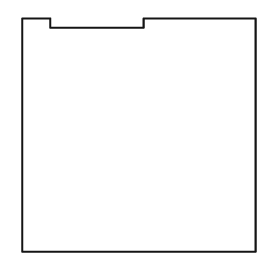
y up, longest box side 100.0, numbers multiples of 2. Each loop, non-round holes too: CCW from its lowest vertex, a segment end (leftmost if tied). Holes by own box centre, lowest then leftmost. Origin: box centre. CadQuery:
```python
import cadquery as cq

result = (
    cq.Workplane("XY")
    .moveTo(-50.0, -50.0)
    .lineTo(50.0, -50.0)
    .lineTo(50.0, 50.0)
    .lineTo(2.0, 50.0)
    .lineTo(2.0, 46.0)
    .lineTo(-38.0, 46.0)
    .lineTo(-38.0, 50.0)
    .lineTo(-50.0, 50.0)
    .close()
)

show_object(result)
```